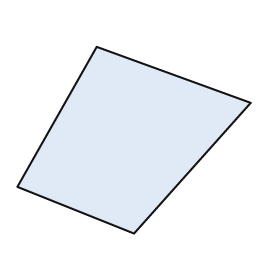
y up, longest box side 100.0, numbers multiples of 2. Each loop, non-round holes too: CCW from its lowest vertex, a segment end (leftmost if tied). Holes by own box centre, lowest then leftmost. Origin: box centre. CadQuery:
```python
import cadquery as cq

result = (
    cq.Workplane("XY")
    .moveTo(0.0, -40.0)
    .lineTo(50.0, 16.0)
    .lineTo(-16.0, 40.0)
    .lineTo(-50.0, -20.0)
    .close()
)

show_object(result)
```